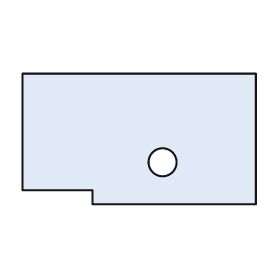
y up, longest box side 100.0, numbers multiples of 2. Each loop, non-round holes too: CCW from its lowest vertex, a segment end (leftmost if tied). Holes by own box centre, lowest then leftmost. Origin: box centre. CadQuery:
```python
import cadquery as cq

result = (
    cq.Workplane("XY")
    .moveTo(-20.0, -28.0)
    .lineTo(50.0, -28.0)
    .lineTo(50.0, 28.0)
    .lineTo(-50.0, 28.0)
    .lineTo(-50.0, -22.0)
    .lineTo(-20.0, -22.0)
    .close()
    .moveTo(10.0, -10.0)
    .circle(6.0)
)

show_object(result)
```